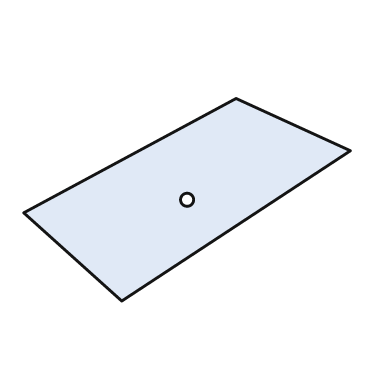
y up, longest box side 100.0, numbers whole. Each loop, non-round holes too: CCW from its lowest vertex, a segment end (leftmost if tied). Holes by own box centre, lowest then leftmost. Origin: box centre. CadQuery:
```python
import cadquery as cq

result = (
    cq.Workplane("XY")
    .moveTo(-20.0, -31.0)
    .lineTo(50.0, 15.0)
    .lineTo(15.0, 31.0)
    .lineTo(-50.0, -4.0)
    .close()
    .moveTo(0.0, 0.0)
    .circle(2.0)
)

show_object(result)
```